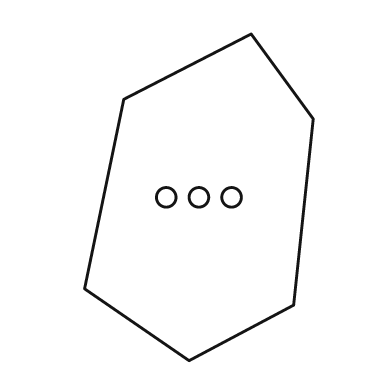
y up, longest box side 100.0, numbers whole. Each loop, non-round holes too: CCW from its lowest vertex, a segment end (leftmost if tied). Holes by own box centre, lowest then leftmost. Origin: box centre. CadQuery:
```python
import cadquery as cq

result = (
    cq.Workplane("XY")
    .moveTo(-3.0, -50.0)
    .lineTo(29.0, -33.0)
    .lineTo(35.0, 24.0)
    .lineTo(16.0, 50.0)
    .lineTo(-23.0, 30.0)
    .lineTo(-35.0, -28.0)
    .close()
    .moveTo(-10.0, 0.0)
    .circle(3.0)
    .moveTo(0.0, 0.0)
    .circle(3.0)
    .moveTo(10.0, 0.0)
    .circle(3.0)
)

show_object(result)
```